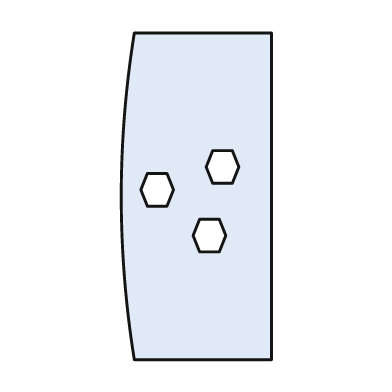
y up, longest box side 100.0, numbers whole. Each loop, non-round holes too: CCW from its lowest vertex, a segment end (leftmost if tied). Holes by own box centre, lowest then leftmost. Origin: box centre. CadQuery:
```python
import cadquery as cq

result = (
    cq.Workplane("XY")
    .moveTo(-19.0, -50.0)
    .lineTo(23.0, -50.0)
    .lineTo(23.0, 50.0)
    .lineTo(-19.0, 50.0)
    .threePointArc((-23.0, 0.0), (-19.0, -50.0))
    .close()
    .moveTo(1.0, -17.0)
    .lineTo(7.0, -17.0)
    .lineTo(9.0, -12.0)
    .lineTo(7.0, -7.0)
    .lineTo(1.0, -7.0)
    .lineTo(-1.0, -12.0)
    .close()
    .moveTo(-15.0, -3.0)
    .lineTo(-9.0, -3.0)
    .lineTo(-7.0, 2.0)
    .lineTo(-9.0, 7.0)
    .lineTo(-15.0, 7.0)
    .lineTo(-17.0, 2.0)
    .close()
    .moveTo(5.0, 4.0)
    .lineTo(11.0, 4.0)
    .lineTo(13.0, 9.0)
    .lineTo(11.0, 14.0)
    .lineTo(5.0, 14.0)
    .lineTo(3.0, 9.0)
    .close()
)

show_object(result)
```